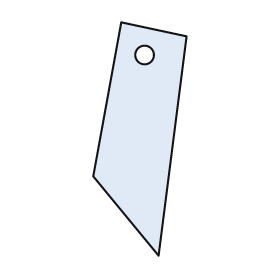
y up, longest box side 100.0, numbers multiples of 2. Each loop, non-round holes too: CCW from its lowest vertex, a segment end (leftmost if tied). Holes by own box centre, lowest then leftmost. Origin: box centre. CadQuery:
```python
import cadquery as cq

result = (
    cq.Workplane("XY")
    .moveTo(8.0, -50.0)
    .lineTo(20.0, 44.0)
    .lineTo(-8.0, 50.0)
    .lineTo(-20.0, -16.0)
    .close()
    .moveTo(2.0, 36.0)
    .circle(4.0)
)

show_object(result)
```